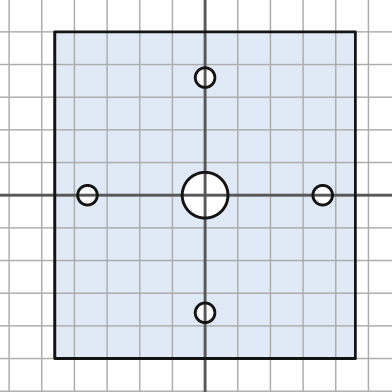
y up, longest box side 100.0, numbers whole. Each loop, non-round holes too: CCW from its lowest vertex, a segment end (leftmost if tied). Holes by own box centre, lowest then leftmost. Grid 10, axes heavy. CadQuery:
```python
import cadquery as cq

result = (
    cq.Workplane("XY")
    .moveTo(-46.0, -50.0)
    .lineTo(46.0, -50.0)
    .lineTo(46.0, 50.0)
    .lineTo(-46.0, 50.0)
    .close()
    .moveTo(0.0, -36.0)
    .circle(3.0)
    .moveTo(-36.0, 0.0)
    .circle(3.0)
    .moveTo(0.0, 0.0)
    .circle(7.0)
    .moveTo(36.0, 0.0)
    .circle(3.0)
    .moveTo(0.0, 36.0)
    .circle(3.0)
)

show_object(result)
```